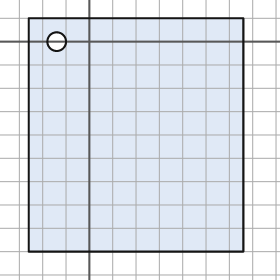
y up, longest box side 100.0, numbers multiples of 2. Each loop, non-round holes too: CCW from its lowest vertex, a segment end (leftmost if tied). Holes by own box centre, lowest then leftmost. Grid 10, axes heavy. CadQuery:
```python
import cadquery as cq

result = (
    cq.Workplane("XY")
    .moveTo(-26.0, -90.0)
    .lineTo(66.0, -90.0)
    .lineTo(66.0, 10.0)
    .lineTo(-26.0, 10.0)
    .close()
    .moveTo(-14.0, 0.0)
    .circle(4.0)
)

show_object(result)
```